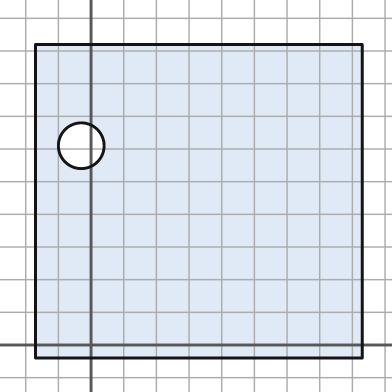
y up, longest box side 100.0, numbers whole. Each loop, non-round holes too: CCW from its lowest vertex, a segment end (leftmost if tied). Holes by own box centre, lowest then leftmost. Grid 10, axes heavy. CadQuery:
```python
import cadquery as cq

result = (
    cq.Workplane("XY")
    .moveTo(-17.0, -4.0)
    .lineTo(83.0, -4.0)
    .lineTo(83.0, 92.0)
    .lineTo(-17.0, 92.0)
    .close()
    .moveTo(-3.0, 61.0)
    .circle(7.0)
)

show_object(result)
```